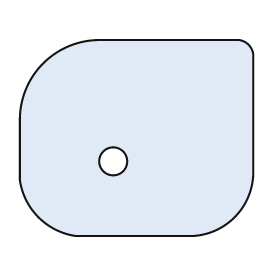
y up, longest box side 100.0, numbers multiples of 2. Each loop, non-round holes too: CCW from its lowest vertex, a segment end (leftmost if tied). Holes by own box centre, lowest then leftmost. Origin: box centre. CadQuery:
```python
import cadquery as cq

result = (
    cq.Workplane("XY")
    .moveTo(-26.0, -42.0)
    .lineTo(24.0, -42.0)
    .threePointArc((42.0, -34.0), (50.0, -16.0))
    .lineTo(50.0, 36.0)
    .threePointArc((48.0, 40.0), (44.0, 42.0))
    .lineTo(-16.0, 42.0)
    .threePointArc((-40.0, 32.0), (-50.0, 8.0))
    .lineTo(-50.0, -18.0)
    .threePointArc((-42.0, -34.0), (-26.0, -42.0))
    .close()
    .moveTo(-10.0, -10.0)
    .circle(6.0)
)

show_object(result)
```